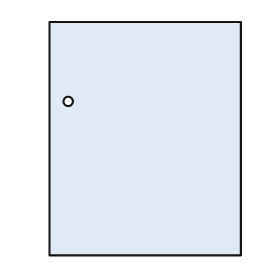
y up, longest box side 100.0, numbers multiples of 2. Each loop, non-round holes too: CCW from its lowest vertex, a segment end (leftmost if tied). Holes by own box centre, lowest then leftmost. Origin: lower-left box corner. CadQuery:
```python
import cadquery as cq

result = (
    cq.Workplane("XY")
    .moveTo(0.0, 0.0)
    .lineTo(82.0, 0.0)
    .lineTo(82.0, 100.0)
    .lineTo(0.0, 100.0)
    .close()
    .moveTo(8.0, 66.0)
    .circle(2.0)
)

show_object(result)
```